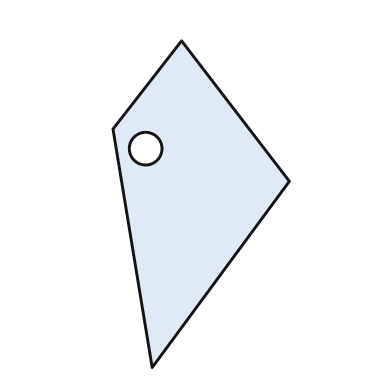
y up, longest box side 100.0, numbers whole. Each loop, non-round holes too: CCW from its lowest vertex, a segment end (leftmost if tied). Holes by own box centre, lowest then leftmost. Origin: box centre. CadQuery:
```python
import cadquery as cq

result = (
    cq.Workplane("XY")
    .moveTo(-15.0, -50.0)
    .lineTo(27.0, 7.0)
    .lineTo(-6.0, 50.0)
    .lineTo(-27.0, 23.0)
    .close()
    .moveTo(-17.0, 17.0)
    .circle(5.0)
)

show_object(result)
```